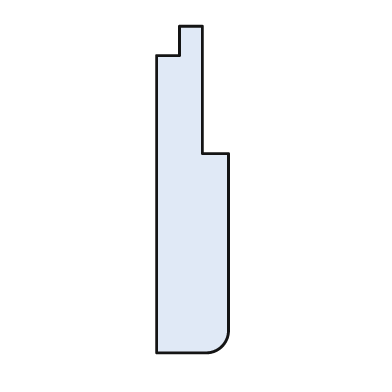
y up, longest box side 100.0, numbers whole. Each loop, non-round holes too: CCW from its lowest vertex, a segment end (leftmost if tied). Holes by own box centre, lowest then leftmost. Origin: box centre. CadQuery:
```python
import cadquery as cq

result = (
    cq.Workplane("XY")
    .moveTo(-11.0, -50.0)
    .lineTo(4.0, -50.0)
    .threePointArc((9.0, -48.0), (11.0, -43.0))
    .lineTo(11.0, 11.0)
    .lineTo(3.0, 11.0)
    .lineTo(3.0, 50.0)
    .lineTo(-4.0, 50.0)
    .lineTo(-4.0, 41.0)
    .lineTo(-11.0, 41.0)
    .close()
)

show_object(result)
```